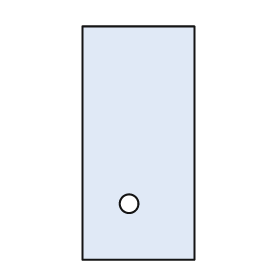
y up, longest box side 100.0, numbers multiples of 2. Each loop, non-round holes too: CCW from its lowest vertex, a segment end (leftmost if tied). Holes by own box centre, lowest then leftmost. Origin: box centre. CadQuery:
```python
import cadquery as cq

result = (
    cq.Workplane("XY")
    .moveTo(-24.0, -50.0)
    .lineTo(24.0, -50.0)
    .lineTo(24.0, 50.0)
    .lineTo(-24.0, 50.0)
    .close()
    .moveTo(-4.0, -26.0)
    .circle(4.0)
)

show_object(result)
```